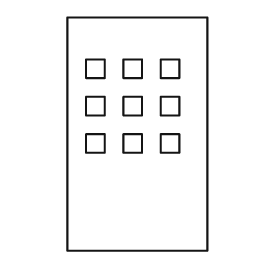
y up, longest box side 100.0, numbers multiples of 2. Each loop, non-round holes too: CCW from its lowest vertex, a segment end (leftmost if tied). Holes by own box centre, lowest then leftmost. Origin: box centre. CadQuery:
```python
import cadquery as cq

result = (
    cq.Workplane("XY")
    .moveTo(-30.0, -50.0)
    .lineTo(30.0, -50.0)
    .lineTo(30.0, 50.0)
    .lineTo(-30.0, 50.0)
    .close()
    .moveTo(-22.0, -8.0)
    .lineTo(-14.0, -8.0)
    .lineTo(-14.0, 0.0)
    .lineTo(-22.0, 0.0)
    .close()
    .moveTo(-6.0, -8.0)
    .lineTo(2.0, -8.0)
    .lineTo(2.0, 0.0)
    .lineTo(-6.0, 0.0)
    .close()
    .moveTo(10.0, -8.0)
    .lineTo(18.0, -8.0)
    .lineTo(18.0, 0.0)
    .lineTo(10.0, 0.0)
    .close()
    .moveTo(-22.0, 8.0)
    .lineTo(-14.0, 8.0)
    .lineTo(-14.0, 16.0)
    .lineTo(-22.0, 16.0)
    .close()
    .moveTo(-6.0, 8.0)
    .lineTo(2.0, 8.0)
    .lineTo(2.0, 16.0)
    .lineTo(-6.0, 16.0)
    .close()
    .moveTo(10.0, 8.0)
    .lineTo(18.0, 8.0)
    .lineTo(18.0, 16.0)
    .lineTo(10.0, 16.0)
    .close()
    .moveTo(-22.0, 24.0)
    .lineTo(-14.0, 24.0)
    .lineTo(-14.0, 32.0)
    .lineTo(-22.0, 32.0)
    .close()
    .moveTo(-6.0, 24.0)
    .lineTo(2.0, 24.0)
    .lineTo(2.0, 32.0)
    .lineTo(-6.0, 32.0)
    .close()
    .moveTo(10.0, 24.0)
    .lineTo(18.0, 24.0)
    .lineTo(18.0, 32.0)
    .lineTo(10.0, 32.0)
    .close()
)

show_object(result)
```